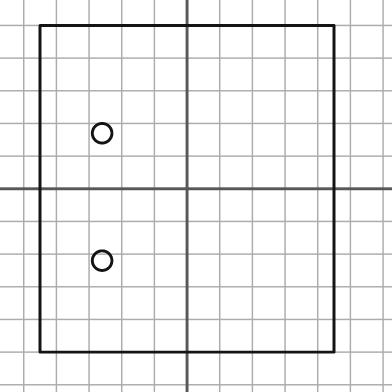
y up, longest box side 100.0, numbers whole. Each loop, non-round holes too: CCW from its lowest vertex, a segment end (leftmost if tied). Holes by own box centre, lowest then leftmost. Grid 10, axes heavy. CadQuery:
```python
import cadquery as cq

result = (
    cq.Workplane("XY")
    .moveTo(-45.0, -50.0)
    .lineTo(45.0, -50.0)
    .lineTo(45.0, 50.0)
    .lineTo(-45.0, 50.0)
    .close()
    .moveTo(-26.0, -22.0)
    .circle(3.0)
    .moveTo(-26.0, 17.0)
    .circle(3.0)
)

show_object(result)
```